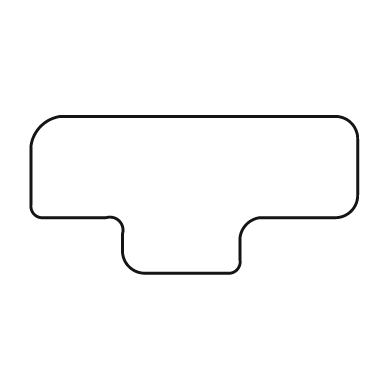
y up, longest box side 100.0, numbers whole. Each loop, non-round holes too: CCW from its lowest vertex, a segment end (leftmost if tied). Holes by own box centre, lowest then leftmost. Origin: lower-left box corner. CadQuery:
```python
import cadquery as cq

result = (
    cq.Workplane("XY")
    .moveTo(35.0, 0.0)
    .lineTo(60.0, 0.0)
    .threePointArc((63.0, 1.0), (64.0, 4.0))
    .lineTo(64.0, 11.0)
    .threePointArc((66.0, 15.0), (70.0, 17.0))
    .lineTo(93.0, 17.0)
    .threePointArc((98.0, 19.0), (100.0, 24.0))
    .lineTo(100.0, 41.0)
    .threePointArc((98.0, 46.0), (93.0, 48.0))
    .lineTo(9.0, 48.0)
    .threePointArc((3.0, 45.0), (0.0, 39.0))
    .lineTo(0.0, 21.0)
    .threePointArc((1.0, 18.0), (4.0, 17.0))
    .lineTo(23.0, 17.0)
    .threePointArc((27.0, 16.0), (28.0, 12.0))
    .lineTo(28.0, 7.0)
    .threePointArc((30.0, 2.0), (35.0, 0.0))
    .close()
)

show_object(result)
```